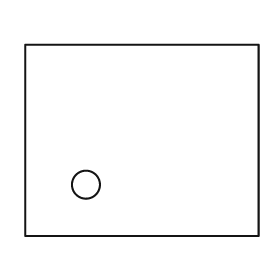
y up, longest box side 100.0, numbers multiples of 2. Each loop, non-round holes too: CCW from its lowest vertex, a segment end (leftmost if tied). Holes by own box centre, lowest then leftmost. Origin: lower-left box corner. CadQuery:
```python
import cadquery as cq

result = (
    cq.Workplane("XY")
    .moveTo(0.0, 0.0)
    .lineTo(100.0, 0.0)
    .lineTo(100.0, 82.0)
    .lineTo(0.0, 82.0)
    .close()
    .moveTo(26.0, 22.0)
    .circle(6.0)
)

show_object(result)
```